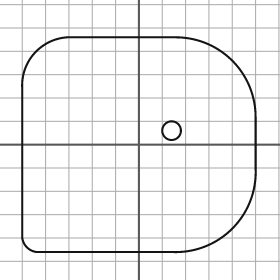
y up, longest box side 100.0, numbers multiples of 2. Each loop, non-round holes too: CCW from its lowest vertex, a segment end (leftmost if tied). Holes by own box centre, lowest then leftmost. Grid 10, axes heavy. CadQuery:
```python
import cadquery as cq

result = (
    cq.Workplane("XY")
    .moveTo(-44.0, -46.0)
    .lineTo(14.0, -46.0)
    .threePointArc((40.0, -36.0), (50.0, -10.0))
    .lineTo(50.0, 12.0)
    .threePointArc((40.0, 36.0), (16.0, 46.0))
    .lineTo(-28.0, 46.0)
    .threePointArc((-44.0, 40.0), (-50.0, 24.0))
    .lineTo(-50.0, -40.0)
    .threePointArc((-48.0, -44.0), (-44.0, -46.0))
    .close()
    .moveTo(14.0, 6.0)
    .circle(4.0)
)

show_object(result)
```